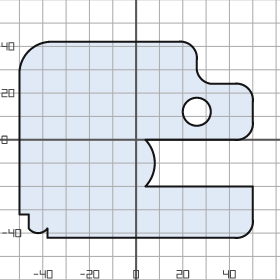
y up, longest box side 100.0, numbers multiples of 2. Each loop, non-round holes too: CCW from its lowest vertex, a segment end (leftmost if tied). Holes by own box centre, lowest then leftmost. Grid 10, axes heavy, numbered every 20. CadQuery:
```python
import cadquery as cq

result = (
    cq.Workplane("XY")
    .moveTo(-38.0, -42.0)
    .lineTo(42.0, -42.0)
    .threePointArc((48.0, -40.0), (50.0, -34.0))
    .lineTo(50.0, -20.0)
    .lineTo(4.0, -20.0)
    .threePointArc((8.0, -10.0), (4.0, 0.0))
    .lineTo(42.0, 0.0)
    .threePointArc((48.0, 2.0), (50.0, 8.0))
    .lineTo(50.0, 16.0)
    .threePointArc((48.0, 22.0), (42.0, 24.0))
    .lineTo(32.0, 24.0)
    .threePointArc((28.0, 26.0), (26.0, 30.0))
    .lineTo(26.0, 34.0)
    .threePointArc((24.0, 40.0), (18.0, 42.0))
    .lineTo(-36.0, 42.0)
    .threePointArc((-46.0, 38.0), (-50.0, 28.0))
    .lineTo(-50.0, -32.0)
    .lineTo(-46.0, -32.0)
    .lineTo(-46.0, -38.0)
    .threePointArc((-42.0, -40.0), (-38.0, -38.0))
    .close()
    .moveTo(26.0, 12.0)
    .circle(6.0)
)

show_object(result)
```